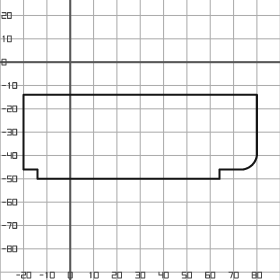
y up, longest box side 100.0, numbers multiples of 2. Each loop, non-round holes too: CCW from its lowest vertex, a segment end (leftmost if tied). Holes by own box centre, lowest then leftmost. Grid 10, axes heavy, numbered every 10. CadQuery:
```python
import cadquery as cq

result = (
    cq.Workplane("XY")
    .moveTo(-14.0, -50.0)
    .lineTo(64.0, -50.0)
    .lineTo(64.0, -46.0)
    .lineTo(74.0, -46.0)
    .threePointArc((78.0, -44.0), (80.0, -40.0))
    .lineTo(80.0, -14.0)
    .lineTo(-20.0, -14.0)
    .lineTo(-20.0, -46.0)
    .lineTo(-14.0, -46.0)
    .close()
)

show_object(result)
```